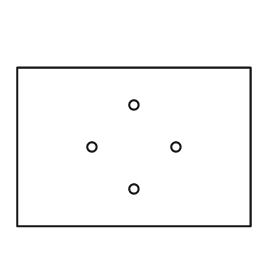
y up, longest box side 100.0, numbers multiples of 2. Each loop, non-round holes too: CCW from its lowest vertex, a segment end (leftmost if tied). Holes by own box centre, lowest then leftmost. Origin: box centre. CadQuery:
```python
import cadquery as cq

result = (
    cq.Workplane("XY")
    .moveTo(-50.0, -34.0)
    .lineTo(50.0, -34.0)
    .lineTo(50.0, 34.0)
    .lineTo(-50.0, 34.0)
    .close()
    .moveTo(0.0, -18.0)
    .circle(2.0)
    .moveTo(-18.0, 0.0)
    .circle(2.0)
    .moveTo(18.0, 0.0)
    .circle(2.0)
    .moveTo(0.0, 18.0)
    .circle(2.0)
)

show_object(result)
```